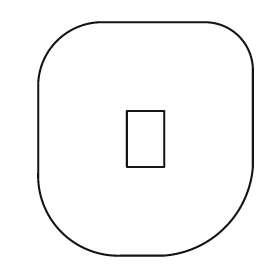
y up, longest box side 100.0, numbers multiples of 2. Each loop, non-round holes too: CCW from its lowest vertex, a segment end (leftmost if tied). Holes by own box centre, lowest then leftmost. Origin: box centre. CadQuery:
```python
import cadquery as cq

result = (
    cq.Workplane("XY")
    .moveTo(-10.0, -50.0)
    .lineTo(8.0, -50.0)
    .threePointArc((34.0, -38.0), (46.0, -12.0))
    .lineTo(46.0, 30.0)
    .threePointArc((40.0, 44.0), (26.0, 50.0))
    .lineTo(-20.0, 50.0)
    .threePointArc((-38.0, 42.0), (-46.0, 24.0))
    .lineTo(-46.0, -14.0)
    .threePointArc((-36.0, -40.0), (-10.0, -50.0))
    .close()
    .moveTo(-8.0, -12.0)
    .lineTo(8.0, -12.0)
    .lineTo(8.0, 12.0)
    .lineTo(-8.0, 12.0)
    .close()
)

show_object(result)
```